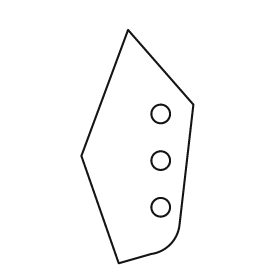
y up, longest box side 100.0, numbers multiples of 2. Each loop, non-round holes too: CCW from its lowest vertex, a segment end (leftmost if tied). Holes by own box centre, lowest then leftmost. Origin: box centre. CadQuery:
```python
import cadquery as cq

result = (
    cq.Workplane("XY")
    .moveTo(-8.0, -50.0)
    .lineTo(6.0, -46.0)
    .threePointArc((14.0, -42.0), (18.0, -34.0))
    .lineTo(24.0, 18.0)
    .lineTo(-4.0, 50.0)
    .lineTo(-24.0, -4.0)
    .close()
    .moveTo(10.0, -26.0)
    .circle(4.0)
    .moveTo(10.0, -6.0)
    .circle(4.0)
    .moveTo(10.0, 14.0)
    .circle(4.0)
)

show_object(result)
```